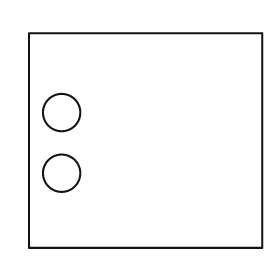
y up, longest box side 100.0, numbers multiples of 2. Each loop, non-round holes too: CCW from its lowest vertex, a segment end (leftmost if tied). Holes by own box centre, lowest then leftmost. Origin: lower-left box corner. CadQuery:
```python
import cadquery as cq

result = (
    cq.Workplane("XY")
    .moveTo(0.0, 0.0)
    .lineTo(100.0, 0.0)
    .lineTo(100.0, 92.0)
    .lineTo(0.0, 92.0)
    .close()
    .moveTo(14.0, 32.0)
    .circle(8.0)
    .moveTo(14.0, 58.0)
    .circle(8.0)
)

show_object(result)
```